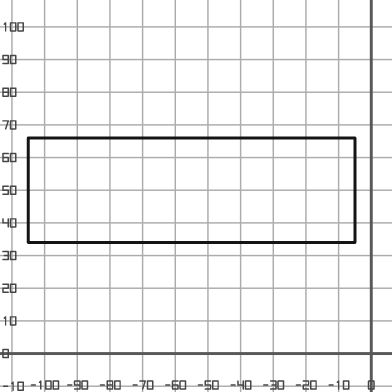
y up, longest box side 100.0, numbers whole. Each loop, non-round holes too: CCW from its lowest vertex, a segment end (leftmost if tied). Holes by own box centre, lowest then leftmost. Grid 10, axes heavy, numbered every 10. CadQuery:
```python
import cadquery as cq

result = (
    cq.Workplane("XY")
    .moveTo(-105.0, 34.0)
    .lineTo(-5.0, 34.0)
    .lineTo(-5.0, 66.0)
    .lineTo(-105.0, 66.0)
    .close()
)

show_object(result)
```